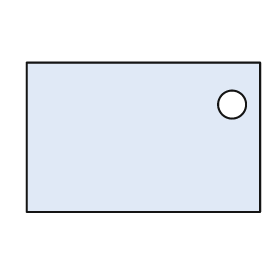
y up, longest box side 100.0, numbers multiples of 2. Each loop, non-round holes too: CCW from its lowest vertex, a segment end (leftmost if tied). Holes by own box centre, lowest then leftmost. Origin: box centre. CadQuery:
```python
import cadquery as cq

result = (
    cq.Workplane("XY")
    .moveTo(-50.0, -32.0)
    .lineTo(50.0, -32.0)
    .lineTo(50.0, 32.0)
    .lineTo(-50.0, 32.0)
    .close()
    .moveTo(38.0, 14.0)
    .circle(6.0)
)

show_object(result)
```